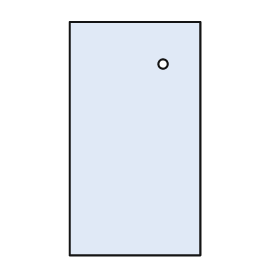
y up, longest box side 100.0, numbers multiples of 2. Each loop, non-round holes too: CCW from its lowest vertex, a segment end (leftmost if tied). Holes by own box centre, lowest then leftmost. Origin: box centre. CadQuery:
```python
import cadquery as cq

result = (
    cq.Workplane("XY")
    .moveTo(-28.0, -50.0)
    .lineTo(28.0, -50.0)
    .lineTo(28.0, 50.0)
    .lineTo(-28.0, 50.0)
    .close()
    .moveTo(12.0, 32.0)
    .circle(2.0)
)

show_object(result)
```